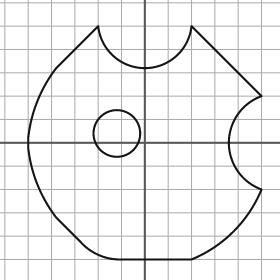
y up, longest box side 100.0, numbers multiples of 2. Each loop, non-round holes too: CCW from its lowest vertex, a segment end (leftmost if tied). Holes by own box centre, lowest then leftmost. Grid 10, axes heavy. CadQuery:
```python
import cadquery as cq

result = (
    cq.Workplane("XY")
    .moveTo(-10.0, -50.0)
    .lineTo(20.0, -50.0)
    .threePointArc((38.0, -38.0), (50.0, -20.0))
    .threePointArc((36.0, 0.0), (50.0, 20.0))
    .lineTo(20.0, 50.0)
    .threePointArc((0.0, 32.0), (-20.0, 50.0))
    .lineTo(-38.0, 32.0)
    .threePointArc((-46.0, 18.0), (-50.0, 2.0))
    .lineTo(-50.0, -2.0)
    .threePointArc((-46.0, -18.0), (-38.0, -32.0))
    .lineTo(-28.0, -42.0)
    .threePointArc((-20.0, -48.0), (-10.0, -50.0))
    .close()
    .moveTo(-12.0, 4.0)
    .circle(10.0)
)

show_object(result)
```